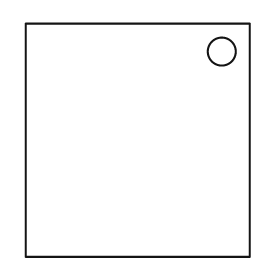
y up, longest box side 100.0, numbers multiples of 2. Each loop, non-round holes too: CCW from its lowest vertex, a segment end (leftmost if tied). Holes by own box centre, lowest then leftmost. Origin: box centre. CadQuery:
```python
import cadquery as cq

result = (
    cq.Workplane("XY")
    .moveTo(-48.0, -50.0)
    .lineTo(48.0, -50.0)
    .lineTo(48.0, 50.0)
    .lineTo(-48.0, 50.0)
    .close()
    .moveTo(36.0, 38.0)
    .circle(6.0)
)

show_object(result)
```